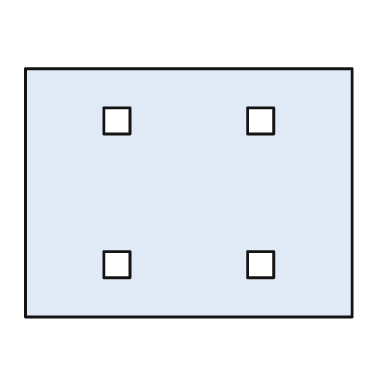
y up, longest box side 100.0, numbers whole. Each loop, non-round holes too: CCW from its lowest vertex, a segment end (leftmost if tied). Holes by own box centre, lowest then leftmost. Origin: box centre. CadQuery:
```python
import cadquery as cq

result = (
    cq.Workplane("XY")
    .moveTo(-50.0, -38.0)
    .lineTo(50.0, -38.0)
    .lineTo(50.0, 38.0)
    .lineTo(-50.0, 38.0)
    .close()
    .moveTo(-26.0, -26.0)
    .lineTo(-18.0, -26.0)
    .lineTo(-18.0, -18.0)
    .lineTo(-26.0, -18.0)
    .close()
    .moveTo(18.0, -26.0)
    .lineTo(26.0, -26.0)
    .lineTo(26.0, -18.0)
    .lineTo(18.0, -18.0)
    .close()
    .moveTo(-26.0, 18.0)
    .lineTo(-18.0, 18.0)
    .lineTo(-18.0, 26.0)
    .lineTo(-26.0, 26.0)
    .close()
    .moveTo(18.0, 18.0)
    .lineTo(26.0, 18.0)
    .lineTo(26.0, 26.0)
    .lineTo(18.0, 26.0)
    .close()
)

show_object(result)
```